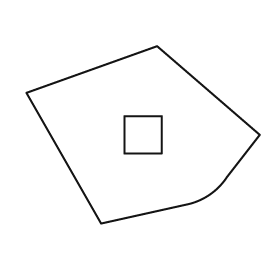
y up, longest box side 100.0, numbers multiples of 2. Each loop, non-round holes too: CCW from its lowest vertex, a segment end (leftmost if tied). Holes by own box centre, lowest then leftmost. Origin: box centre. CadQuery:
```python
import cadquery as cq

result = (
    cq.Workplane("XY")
    .moveTo(-18.0, -38.0)
    .lineTo(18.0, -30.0)
    .threePointArc((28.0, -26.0), (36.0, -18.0))
    .lineTo(50.0, 0.0)
    .lineTo(6.0, 38.0)
    .lineTo(-50.0, 18.0)
    .close()
    .moveTo(-8.0, -8.0)
    .lineTo(8.0, -8.0)
    .lineTo(8.0, 8.0)
    .lineTo(-8.0, 8.0)
    .close()
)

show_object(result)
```